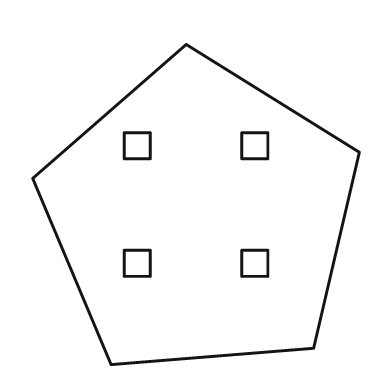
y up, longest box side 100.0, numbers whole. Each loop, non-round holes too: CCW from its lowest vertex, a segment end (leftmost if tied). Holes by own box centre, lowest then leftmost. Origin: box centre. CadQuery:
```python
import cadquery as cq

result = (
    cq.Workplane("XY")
    .moveTo(-26.0, -49.0)
    .lineTo(36.0, -44.0)
    .lineTo(50.0, 16.0)
    .lineTo(-3.0, 49.0)
    .lineTo(-50.0, 8.0)
    .close()
    .moveTo(-22.0, -22.0)
    .lineTo(-14.0, -22.0)
    .lineTo(-14.0, -14.0)
    .lineTo(-22.0, -14.0)
    .close()
    .moveTo(14.0, -22.0)
    .lineTo(22.0, -22.0)
    .lineTo(22.0, -14.0)
    .lineTo(14.0, -14.0)
    .close()
    .moveTo(-22.0, 14.0)
    .lineTo(-14.0, 14.0)
    .lineTo(-14.0, 22.0)
    .lineTo(-22.0, 22.0)
    .close()
    .moveTo(14.0, 14.0)
    .lineTo(22.0, 14.0)
    .lineTo(22.0, 22.0)
    .lineTo(14.0, 22.0)
    .close()
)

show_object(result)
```